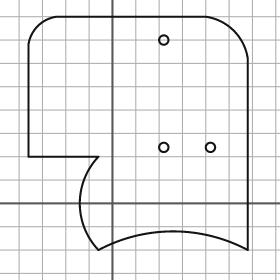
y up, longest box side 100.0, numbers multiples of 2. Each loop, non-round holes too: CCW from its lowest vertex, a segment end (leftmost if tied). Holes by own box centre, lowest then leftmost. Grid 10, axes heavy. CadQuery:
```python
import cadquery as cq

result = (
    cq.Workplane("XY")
    .moveTo(-6.0, -20.0)
    .threePointArc((26.0, -12.0), (58.0, -20.0))
    .lineTo(58.0, 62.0)
    .threePointArc((52.0, 74.0), (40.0, 80.0))
    .lineTo(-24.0, 80.0)
    .threePointArc((-32.0, 76.0), (-36.0, 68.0))
    .lineTo(-36.0, 20.0)
    .lineTo(-6.0, 20.0)
    .threePointArc((-14.0, 0.0), (-6.0, -20.0))
    .close()
    .moveTo(22.0, 24.0)
    .circle(2.0)
    .moveTo(42.0, 24.0)
    .circle(2.0)
    .moveTo(22.0, 70.0)
    .circle(2.0)
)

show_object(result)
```